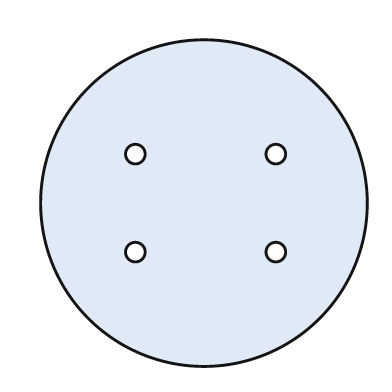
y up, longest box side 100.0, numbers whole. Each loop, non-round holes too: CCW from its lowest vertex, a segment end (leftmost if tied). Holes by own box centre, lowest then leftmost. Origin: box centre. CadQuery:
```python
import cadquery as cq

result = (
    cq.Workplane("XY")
    .moveTo(0.0, 0.0)
    .circle(50.0)
    .moveTo(-21.0, -15.0)
    .circle(3.0)
    .moveTo(22.0, -15.0)
    .circle(3.0)
    .moveTo(-21.0, 15.0)
    .circle(3.0)
    .moveTo(22.0, 15.0)
    .circle(3.0)
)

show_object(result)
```